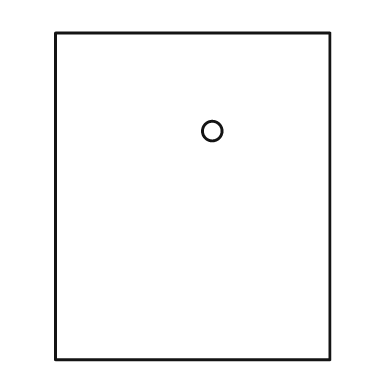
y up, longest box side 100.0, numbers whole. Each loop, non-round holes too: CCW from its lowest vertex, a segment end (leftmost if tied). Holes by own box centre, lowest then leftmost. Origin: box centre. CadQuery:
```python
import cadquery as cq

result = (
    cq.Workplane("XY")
    .moveTo(-42.0, -50.0)
    .lineTo(42.0, -50.0)
    .lineTo(42.0, 50.0)
    .lineTo(-42.0, 50.0)
    .close()
    .moveTo(6.0, 20.0)
    .circle(3.0)
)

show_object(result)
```